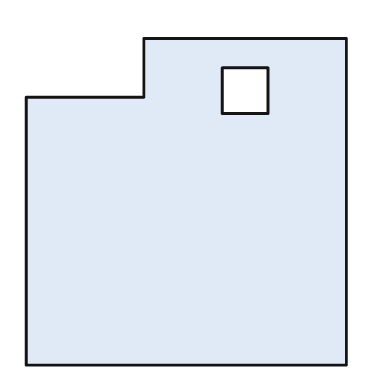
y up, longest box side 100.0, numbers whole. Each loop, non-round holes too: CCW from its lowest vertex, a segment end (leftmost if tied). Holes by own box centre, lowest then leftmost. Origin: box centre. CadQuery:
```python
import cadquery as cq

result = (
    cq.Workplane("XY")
    .moveTo(-49.0, -50.0)
    .lineTo(49.0, -50.0)
    .lineTo(49.0, 50.0)
    .lineTo(-13.0, 50.0)
    .lineTo(-13.0, 32.0)
    .lineTo(-49.0, 32.0)
    .close()
    .moveTo(11.0, 27.0)
    .lineTo(25.0, 27.0)
    .lineTo(25.0, 41.0)
    .lineTo(11.0, 41.0)
    .close()
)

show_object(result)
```